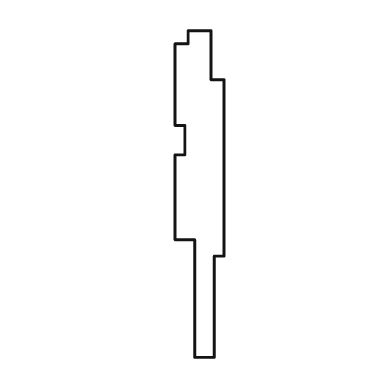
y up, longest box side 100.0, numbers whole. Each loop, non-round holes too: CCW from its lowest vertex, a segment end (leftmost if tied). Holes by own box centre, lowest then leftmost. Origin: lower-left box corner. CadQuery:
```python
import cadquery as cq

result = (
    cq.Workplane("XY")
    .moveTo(6.0, 0.0)
    .lineTo(12.0, 0.0)
    .lineTo(12.0, 31.0)
    .lineTo(15.0, 31.0)
    .lineTo(15.0, 85.0)
    .lineTo(11.0, 85.0)
    .lineTo(11.0, 100.0)
    .lineTo(4.0, 100.0)
    .lineTo(4.0, 96.0)
    .lineTo(0.0, 96.0)
    .lineTo(0.0, 71.0)
    .lineTo(3.0, 71.0)
    .lineTo(3.0, 62.0)
    .lineTo(0.0, 62.0)
    .lineTo(0.0, 36.0)
    .lineTo(6.0, 36.0)
    .close()
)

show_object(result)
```